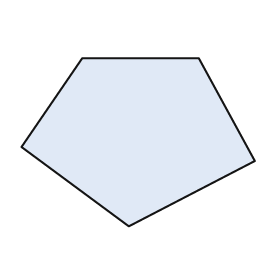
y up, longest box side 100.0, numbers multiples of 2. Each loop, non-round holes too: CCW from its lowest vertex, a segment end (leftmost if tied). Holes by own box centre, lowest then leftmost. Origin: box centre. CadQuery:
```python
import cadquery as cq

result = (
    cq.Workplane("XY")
    .moveTo(-4.0, -36.0)
    .lineTo(50.0, -8.0)
    .lineTo(26.0, 36.0)
    .lineTo(-24.0, 36.0)
    .lineTo(-50.0, -2.0)
    .close()
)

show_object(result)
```